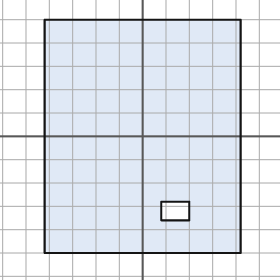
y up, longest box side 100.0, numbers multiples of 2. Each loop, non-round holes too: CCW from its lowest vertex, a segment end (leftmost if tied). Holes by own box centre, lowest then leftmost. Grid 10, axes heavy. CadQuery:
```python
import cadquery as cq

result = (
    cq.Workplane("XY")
    .moveTo(-42.0, -50.0)
    .lineTo(42.0, -50.0)
    .lineTo(42.0, 50.0)
    .lineTo(-42.0, 50.0)
    .close()
    .moveTo(8.0, -36.0)
    .lineTo(20.0, -36.0)
    .lineTo(20.0, -28.0)
    .lineTo(8.0, -28.0)
    .close()
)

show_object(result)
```